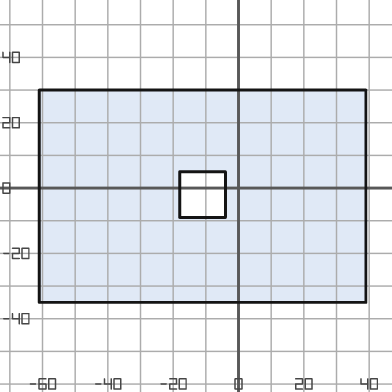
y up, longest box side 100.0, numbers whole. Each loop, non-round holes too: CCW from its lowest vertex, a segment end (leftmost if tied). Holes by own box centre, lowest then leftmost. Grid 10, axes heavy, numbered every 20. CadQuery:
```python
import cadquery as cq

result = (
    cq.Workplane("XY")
    .moveTo(-61.0, -35.0)
    .lineTo(39.0, -35.0)
    .lineTo(39.0, 30.0)
    .lineTo(-61.0, 30.0)
    .close()
    .moveTo(-18.0, -9.0)
    .lineTo(-4.0, -9.0)
    .lineTo(-4.0, 5.0)
    .lineTo(-18.0, 5.0)
    .close()
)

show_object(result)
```